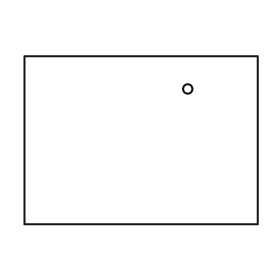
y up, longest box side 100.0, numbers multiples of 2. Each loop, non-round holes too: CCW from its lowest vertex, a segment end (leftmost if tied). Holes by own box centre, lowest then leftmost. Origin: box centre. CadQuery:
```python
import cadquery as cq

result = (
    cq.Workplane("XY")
    .moveTo(-50.0, -36.0)
    .lineTo(50.0, -36.0)
    .lineTo(50.0, 36.0)
    .lineTo(-50.0, 36.0)
    .close()
    .moveTo(20.0, 22.0)
    .circle(2.0)
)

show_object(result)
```